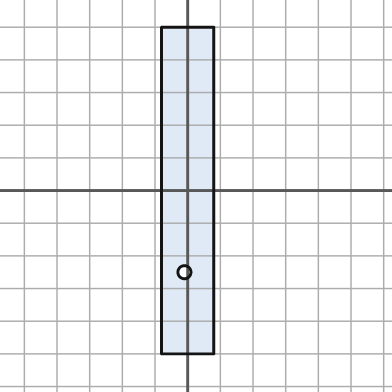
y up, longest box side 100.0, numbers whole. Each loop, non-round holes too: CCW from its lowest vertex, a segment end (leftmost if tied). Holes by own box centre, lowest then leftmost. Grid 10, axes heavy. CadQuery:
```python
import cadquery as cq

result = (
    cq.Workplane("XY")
    .moveTo(-8.0, -50.0)
    .lineTo(8.0, -50.0)
    .lineTo(8.0, 50.0)
    .lineTo(-8.0, 50.0)
    .close()
    .moveTo(-1.0, -25.0)
    .circle(2.0)
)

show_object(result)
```